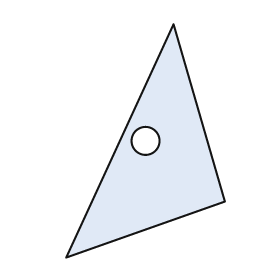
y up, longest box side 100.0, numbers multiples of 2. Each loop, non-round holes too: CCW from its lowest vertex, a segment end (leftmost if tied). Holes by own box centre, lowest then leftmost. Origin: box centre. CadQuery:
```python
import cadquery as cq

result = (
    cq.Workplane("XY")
    .moveTo(-34.0, -50.0)
    .lineTo(34.0, -26.0)
    .lineTo(12.0, 50.0)
    .close()
    .moveTo(0.0, 0.0)
    .circle(6.0)
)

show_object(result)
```